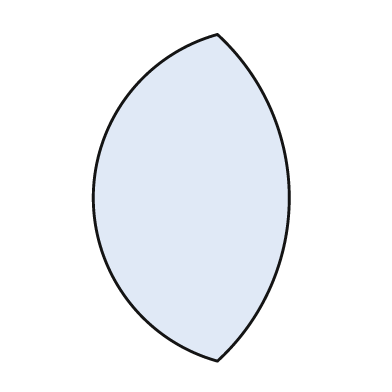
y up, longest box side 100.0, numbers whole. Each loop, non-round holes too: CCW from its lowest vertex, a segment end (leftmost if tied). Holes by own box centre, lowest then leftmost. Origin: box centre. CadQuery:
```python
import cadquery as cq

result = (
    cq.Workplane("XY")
    .moveTo(8.0, -50.0)
    .threePointArc((30.0, 0.0), (8.0, 50.0))
    .threePointArc((-30.0, 0.0), (8.0, -50.0))
    .close()
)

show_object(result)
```